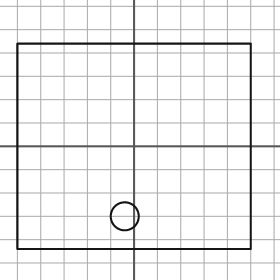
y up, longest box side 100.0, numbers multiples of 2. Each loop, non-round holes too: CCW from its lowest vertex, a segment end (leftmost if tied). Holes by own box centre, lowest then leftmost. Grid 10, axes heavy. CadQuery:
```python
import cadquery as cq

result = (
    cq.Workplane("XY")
    .moveTo(-50.0, -44.0)
    .lineTo(50.0, -44.0)
    .lineTo(50.0, 44.0)
    .lineTo(-50.0, 44.0)
    .close()
    .moveTo(-4.0, -30.0)
    .circle(6.0)
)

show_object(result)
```